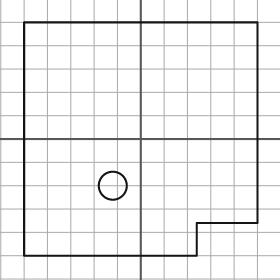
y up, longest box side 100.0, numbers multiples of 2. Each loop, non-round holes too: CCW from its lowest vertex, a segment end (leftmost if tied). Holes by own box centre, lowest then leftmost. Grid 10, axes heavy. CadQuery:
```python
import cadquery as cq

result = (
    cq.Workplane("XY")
    .moveTo(-50.0, -50.0)
    .lineTo(24.0, -50.0)
    .lineTo(24.0, -36.0)
    .lineTo(50.0, -36.0)
    .lineTo(50.0, 50.0)
    .lineTo(-50.0, 50.0)
    .close()
    .moveTo(-12.0, -20.0)
    .circle(6.0)
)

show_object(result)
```